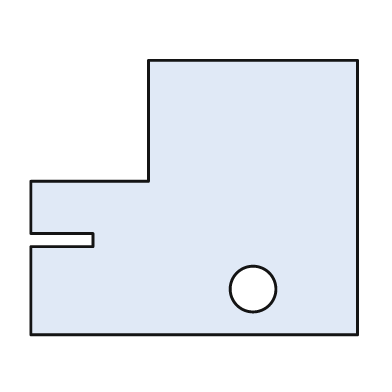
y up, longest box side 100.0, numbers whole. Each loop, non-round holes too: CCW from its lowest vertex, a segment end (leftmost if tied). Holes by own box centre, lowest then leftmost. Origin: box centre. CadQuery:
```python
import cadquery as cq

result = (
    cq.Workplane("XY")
    .moveTo(-50.0, -42.0)
    .lineTo(50.0, -42.0)
    .lineTo(50.0, 42.0)
    .lineTo(-14.0, 42.0)
    .lineTo(-14.0, 5.0)
    .lineTo(-50.0, 5.0)
    .lineTo(-50.0, -11.0)
    .lineTo(-31.0, -11.0)
    .lineTo(-31.0, -15.0)
    .lineTo(-50.0, -15.0)
    .close()
    .moveTo(18.0, -28.0)
    .circle(7.0)
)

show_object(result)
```